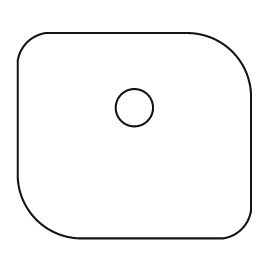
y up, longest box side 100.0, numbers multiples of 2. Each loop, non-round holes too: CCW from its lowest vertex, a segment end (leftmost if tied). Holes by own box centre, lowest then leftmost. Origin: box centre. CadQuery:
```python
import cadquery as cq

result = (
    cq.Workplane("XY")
    .moveTo(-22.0, -44.0)
    .lineTo(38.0, -44.0)
    .threePointArc((46.0, -40.0), (50.0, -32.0))
    .lineTo(50.0, 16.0)
    .threePointArc((42.0, 36.0), (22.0, 44.0))
    .lineTo(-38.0, 44.0)
    .threePointArc((-46.0, 40.0), (-50.0, 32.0))
    .lineTo(-50.0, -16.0)
    .threePointArc((-42.0, -36.0), (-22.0, -44.0))
    .close()
    .moveTo(0.0, 12.0)
    .circle(8.0)
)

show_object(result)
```